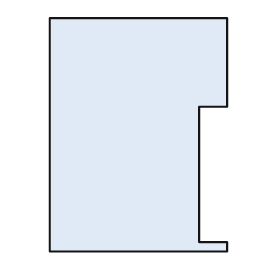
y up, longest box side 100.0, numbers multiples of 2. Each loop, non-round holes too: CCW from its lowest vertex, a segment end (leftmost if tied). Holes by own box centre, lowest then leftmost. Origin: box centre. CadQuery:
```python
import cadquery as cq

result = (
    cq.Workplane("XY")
    .moveTo(-38.0, -50.0)
    .lineTo(38.0, -50.0)
    .lineTo(38.0, -46.0)
    .lineTo(26.0, -46.0)
    .lineTo(26.0, 12.0)
    .lineTo(38.0, 12.0)
    .lineTo(38.0, 50.0)
    .lineTo(-38.0, 50.0)
    .close()
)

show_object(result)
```